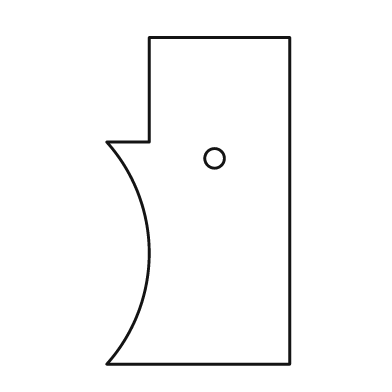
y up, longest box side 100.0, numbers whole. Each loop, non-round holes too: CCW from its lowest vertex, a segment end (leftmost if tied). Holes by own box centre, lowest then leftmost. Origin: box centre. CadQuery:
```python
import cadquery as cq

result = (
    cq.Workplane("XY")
    .moveTo(-28.0, -50.0)
    .lineTo(28.0, -50.0)
    .lineTo(28.0, 50.0)
    .lineTo(-15.0, 50.0)
    .lineTo(-15.0, 18.0)
    .lineTo(-28.0, 18.0)
    .threePointArc((-15.0, -16.0), (-28.0, -50.0))
    .close()
    .moveTo(5.0, 13.0)
    .circle(3.0)
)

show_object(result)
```